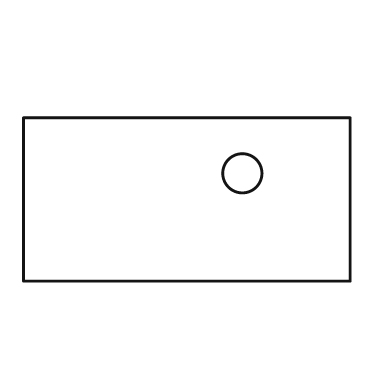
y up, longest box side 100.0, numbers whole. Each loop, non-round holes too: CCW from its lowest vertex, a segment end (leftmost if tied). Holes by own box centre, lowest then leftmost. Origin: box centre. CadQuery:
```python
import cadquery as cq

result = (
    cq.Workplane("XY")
    .moveTo(-50.0, -25.0)
    .lineTo(50.0, -25.0)
    .lineTo(50.0, 25.0)
    .lineTo(-50.0, 25.0)
    .close()
    .moveTo(17.0, 8.0)
    .circle(6.0)
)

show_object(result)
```